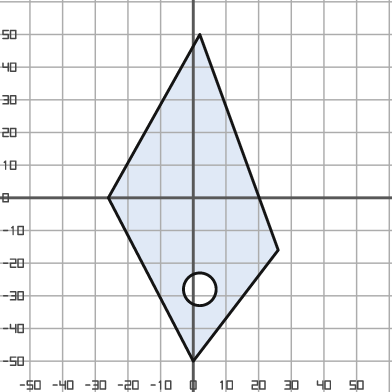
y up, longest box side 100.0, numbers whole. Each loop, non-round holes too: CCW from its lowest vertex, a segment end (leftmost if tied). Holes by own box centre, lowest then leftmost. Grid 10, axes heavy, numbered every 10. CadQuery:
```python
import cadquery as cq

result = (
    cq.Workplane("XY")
    .moveTo(0.0, -50.0)
    .lineTo(26.0, -16.0)
    .lineTo(2.0, 50.0)
    .lineTo(-26.0, 0.0)
    .close()
    .moveTo(2.0, -28.0)
    .circle(5.0)
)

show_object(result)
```